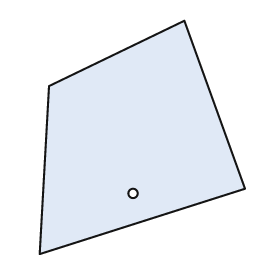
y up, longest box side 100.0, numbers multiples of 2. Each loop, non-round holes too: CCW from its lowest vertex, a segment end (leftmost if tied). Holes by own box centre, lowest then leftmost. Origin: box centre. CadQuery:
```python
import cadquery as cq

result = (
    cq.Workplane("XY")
    .moveTo(-44.0, -50.0)
    .lineTo(44.0, -22.0)
    .lineTo(18.0, 50.0)
    .lineTo(-40.0, 22.0)
    .close()
    .moveTo(-4.0, -24.0)
    .circle(2.0)
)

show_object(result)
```